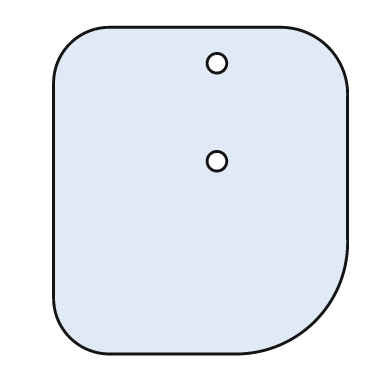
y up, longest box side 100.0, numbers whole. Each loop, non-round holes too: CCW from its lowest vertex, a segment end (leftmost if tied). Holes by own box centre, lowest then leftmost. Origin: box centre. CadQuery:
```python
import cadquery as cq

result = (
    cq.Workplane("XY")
    .moveTo(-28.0, -50.0)
    .lineTo(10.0, -50.0)
    .threePointArc((35.0, -40.0), (45.0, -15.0))
    .lineTo(45.0, 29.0)
    .threePointArc((39.0, 44.0), (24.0, 50.0))
    .lineTo(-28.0, 50.0)
    .threePointArc((-40.0, 45.0), (-45.0, 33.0))
    .lineTo(-45.0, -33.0)
    .threePointArc((-40.0, -45.0), (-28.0, -50.0))
    .close()
    .moveTo(5.0, 9.0)
    .circle(3.0)
    .moveTo(5.0, 39.0)
    .circle(3.0)
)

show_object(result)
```